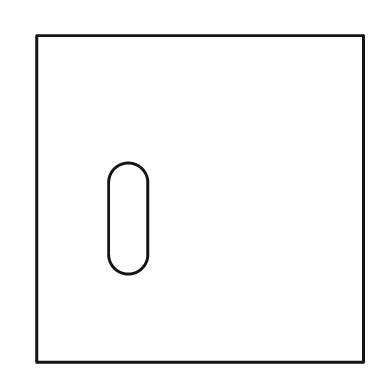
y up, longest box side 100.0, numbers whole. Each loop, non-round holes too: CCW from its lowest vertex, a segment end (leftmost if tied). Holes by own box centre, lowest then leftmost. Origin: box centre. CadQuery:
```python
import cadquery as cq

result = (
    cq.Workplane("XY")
    .moveTo(-50.0, -50.0)
    .lineTo(50.0, -50.0)
    .lineTo(50.0, 50.0)
    .lineTo(-50.0, 50.0)
    .close()
    .moveTo(-28.0, -17.0)
    .threePointArc((-22.0, -23.0), (-16.0, -17.0))
    .lineTo(-16.0, 5.0)
    .threePointArc((-22.0, 11.0), (-28.0, 5.0))
    .close()
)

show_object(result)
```